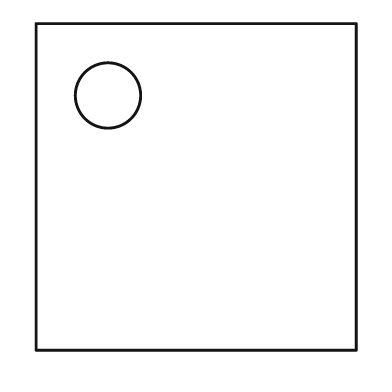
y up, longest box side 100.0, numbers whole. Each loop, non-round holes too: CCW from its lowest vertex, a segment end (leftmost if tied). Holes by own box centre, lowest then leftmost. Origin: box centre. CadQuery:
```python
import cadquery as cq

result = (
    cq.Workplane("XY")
    .moveTo(-49.0, -50.0)
    .lineTo(49.0, -50.0)
    .lineTo(49.0, 50.0)
    .lineTo(-49.0, 50.0)
    .close()
    .moveTo(-27.0, 28.0)
    .circle(10.0)
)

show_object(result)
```